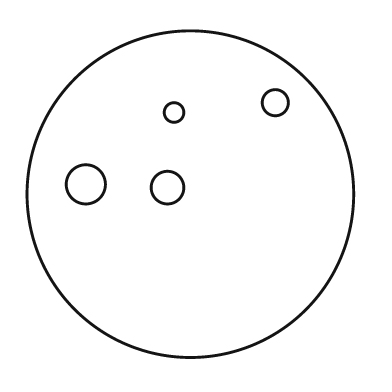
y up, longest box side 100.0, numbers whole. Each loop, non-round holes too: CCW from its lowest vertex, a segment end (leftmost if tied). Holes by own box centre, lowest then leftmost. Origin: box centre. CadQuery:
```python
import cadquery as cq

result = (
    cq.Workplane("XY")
    .moveTo(0.0, 0.0)
    .circle(50.0)
    .moveTo(-7.0, 2.0)
    .circle(5.0)
    .moveTo(-32.0, 3.0)
    .circle(6.0)
    .moveTo(-5.0, 25.0)
    .circle(3.0)
    .moveTo(26.0, 28.0)
    .circle(4.0)
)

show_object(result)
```